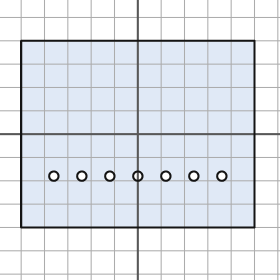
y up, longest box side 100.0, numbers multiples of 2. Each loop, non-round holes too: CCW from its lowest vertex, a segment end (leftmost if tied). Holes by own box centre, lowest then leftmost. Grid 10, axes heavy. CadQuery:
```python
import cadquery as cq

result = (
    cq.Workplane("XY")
    .moveTo(-50.0, -40.0)
    .lineTo(50.0, -40.0)
    .lineTo(50.0, 40.0)
    .lineTo(-50.0, 40.0)
    .close()
    .moveTo(-36.0, -18.0)
    .circle(2.0)
    .moveTo(-24.0, -18.0)
    .circle(2.0)
    .moveTo(-12.0, -18.0)
    .circle(2.0)
    .moveTo(0.0, -18.0)
    .circle(2.0)
    .moveTo(12.0, -18.0)
    .circle(2.0)
    .moveTo(24.0, -18.0)
    .circle(2.0)
    .moveTo(36.0, -18.0)
    .circle(2.0)
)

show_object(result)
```